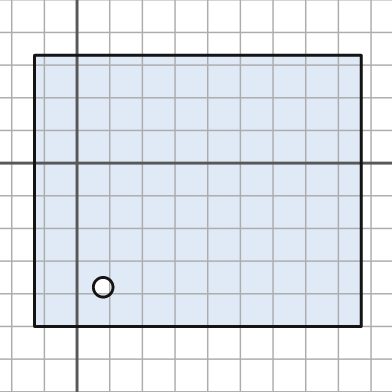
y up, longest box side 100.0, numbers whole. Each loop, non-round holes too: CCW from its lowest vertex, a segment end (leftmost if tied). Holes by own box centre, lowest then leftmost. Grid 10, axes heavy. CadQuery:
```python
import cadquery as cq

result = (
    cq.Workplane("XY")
    .moveTo(-13.0, -50.0)
    .lineTo(87.0, -50.0)
    .lineTo(87.0, 33.0)
    .lineTo(-13.0, 33.0)
    .close()
    .moveTo(8.0, -38.0)
    .circle(3.0)
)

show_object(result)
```